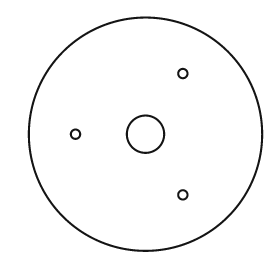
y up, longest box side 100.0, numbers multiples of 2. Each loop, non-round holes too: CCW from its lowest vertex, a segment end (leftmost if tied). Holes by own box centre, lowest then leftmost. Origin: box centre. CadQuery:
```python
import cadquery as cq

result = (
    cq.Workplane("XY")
    .moveTo(0.0, 0.0)
    .circle(50.0)
    .moveTo(16.0, -26.0)
    .circle(2.0)
    .moveTo(-30.0, 0.0)
    .circle(2.0)
    .moveTo(0.0, 0.0)
    .circle(8.0)
    .moveTo(16.0, 26.0)
    .circle(2.0)
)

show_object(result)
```